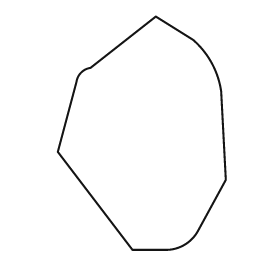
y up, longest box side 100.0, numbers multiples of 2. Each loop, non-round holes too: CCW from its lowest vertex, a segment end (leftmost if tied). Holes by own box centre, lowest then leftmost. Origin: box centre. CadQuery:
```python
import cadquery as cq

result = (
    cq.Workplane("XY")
    .moveTo(-4.0, -50.0)
    .lineTo(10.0, -50.0)
    .threePointArc((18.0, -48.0), (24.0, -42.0))
    .lineTo(36.0, -20.0)
    .lineTo(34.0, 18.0)
    .threePointArc((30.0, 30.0), (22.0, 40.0))
    .lineTo(6.0, 50.0)
    .lineTo(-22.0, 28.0)
    .threePointArc((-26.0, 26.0), (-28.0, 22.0))
    .lineTo(-36.0, -8.0)
    .close()
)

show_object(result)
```